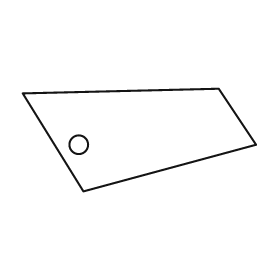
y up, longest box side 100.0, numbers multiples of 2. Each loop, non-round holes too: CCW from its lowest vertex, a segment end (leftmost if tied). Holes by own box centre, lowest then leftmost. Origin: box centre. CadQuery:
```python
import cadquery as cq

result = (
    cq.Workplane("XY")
    .moveTo(-24.0, -22.0)
    .lineTo(50.0, -2.0)
    .lineTo(34.0, 22.0)
    .lineTo(-50.0, 20.0)
    .close()
    .moveTo(-26.0, -2.0)
    .circle(4.0)
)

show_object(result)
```